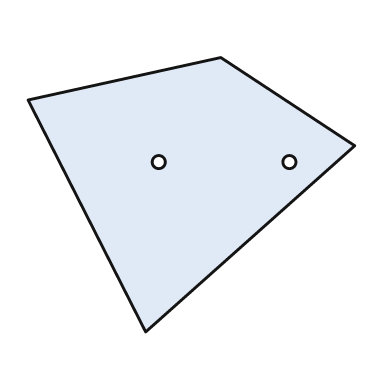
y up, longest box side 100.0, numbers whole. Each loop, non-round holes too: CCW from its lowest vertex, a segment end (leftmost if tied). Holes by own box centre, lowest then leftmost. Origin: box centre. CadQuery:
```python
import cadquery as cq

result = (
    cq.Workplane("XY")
    .moveTo(-14.0, -42.0)
    .lineTo(50.0, 15.0)
    .lineTo(9.0, 42.0)
    .lineTo(-50.0, 29.0)
    .close()
    .moveTo(-10.0, 10.0)
    .circle(2.0)
    .moveTo(30.0, 10.0)
    .circle(2.0)
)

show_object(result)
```